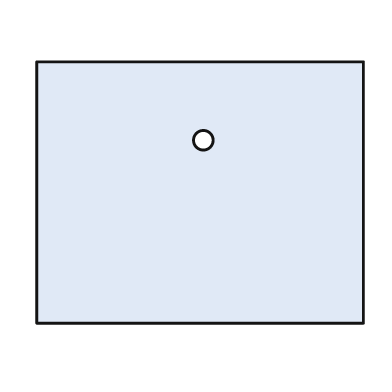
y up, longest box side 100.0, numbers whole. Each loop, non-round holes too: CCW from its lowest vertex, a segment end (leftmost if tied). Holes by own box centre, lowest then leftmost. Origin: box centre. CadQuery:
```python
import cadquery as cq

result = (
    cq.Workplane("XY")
    .moveTo(-50.0, -40.0)
    .lineTo(50.0, -40.0)
    .lineTo(50.0, 40.0)
    .lineTo(-50.0, 40.0)
    .close()
    .moveTo(1.0, 16.0)
    .circle(3.0)
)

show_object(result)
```